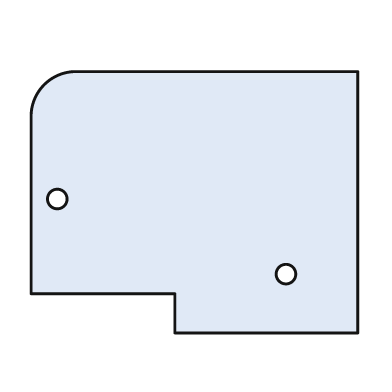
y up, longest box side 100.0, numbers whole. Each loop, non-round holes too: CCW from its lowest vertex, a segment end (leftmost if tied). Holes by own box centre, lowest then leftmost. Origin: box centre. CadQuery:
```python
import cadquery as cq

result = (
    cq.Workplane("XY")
    .moveTo(-6.0, -40.0)
    .lineTo(50.0, -40.0)
    .lineTo(50.0, 40.0)
    .lineTo(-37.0, 40.0)
    .threePointArc((-46.0, 36.0), (-50.0, 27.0))
    .lineTo(-50.0, -28.0)
    .lineTo(-6.0, -28.0)
    .close()
    .moveTo(28.0, -22.0)
    .circle(3.0)
    .moveTo(-42.0, 1.0)
    .circle(3.0)
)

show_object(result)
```